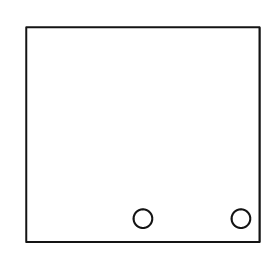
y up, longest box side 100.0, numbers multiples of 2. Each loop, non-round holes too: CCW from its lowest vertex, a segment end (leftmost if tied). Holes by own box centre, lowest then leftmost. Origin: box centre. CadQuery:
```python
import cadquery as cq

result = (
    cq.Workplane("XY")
    .moveTo(-50.0, -46.0)
    .lineTo(50.0, -46.0)
    .lineTo(50.0, 46.0)
    .lineTo(-50.0, 46.0)
    .close()
    .moveTo(0.0, -36.0)
    .circle(4.0)
    .moveTo(42.0, -36.0)
    .circle(4.0)
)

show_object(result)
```